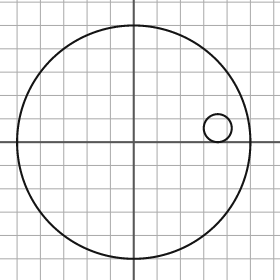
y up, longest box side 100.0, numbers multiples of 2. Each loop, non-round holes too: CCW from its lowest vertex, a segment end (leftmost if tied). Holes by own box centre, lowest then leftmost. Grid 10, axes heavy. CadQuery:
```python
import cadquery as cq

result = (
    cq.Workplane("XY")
    .moveTo(0.0, 0.0)
    .circle(50.0)
    .moveTo(36.0, 6.0)
    .circle(6.0)
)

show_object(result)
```